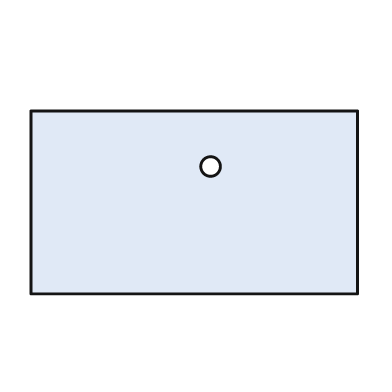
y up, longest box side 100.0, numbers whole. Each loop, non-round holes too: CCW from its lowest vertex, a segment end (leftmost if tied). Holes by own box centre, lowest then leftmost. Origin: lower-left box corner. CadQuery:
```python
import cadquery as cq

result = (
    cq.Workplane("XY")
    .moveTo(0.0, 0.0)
    .lineTo(100.0, 0.0)
    .lineTo(100.0, 56.0)
    .lineTo(0.0, 56.0)
    .close()
    .moveTo(55.0, 39.0)
    .circle(3.0)
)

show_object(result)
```